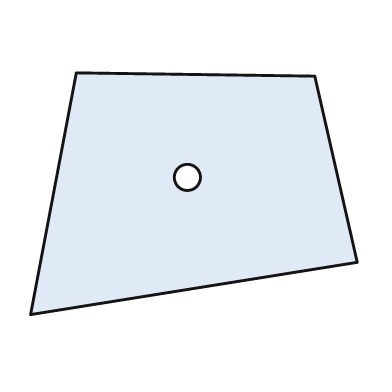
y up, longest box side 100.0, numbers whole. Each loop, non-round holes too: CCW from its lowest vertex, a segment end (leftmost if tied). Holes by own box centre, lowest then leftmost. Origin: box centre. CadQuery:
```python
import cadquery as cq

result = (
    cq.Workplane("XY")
    .moveTo(-50.0, -37.0)
    .lineTo(50.0, -21.0)
    .lineTo(37.0, 36.0)
    .lineTo(-36.0, 37.0)
    .close()
    .moveTo(-2.0, 5.0)
    .circle(4.0)
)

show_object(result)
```